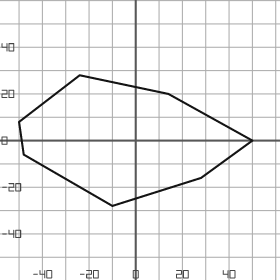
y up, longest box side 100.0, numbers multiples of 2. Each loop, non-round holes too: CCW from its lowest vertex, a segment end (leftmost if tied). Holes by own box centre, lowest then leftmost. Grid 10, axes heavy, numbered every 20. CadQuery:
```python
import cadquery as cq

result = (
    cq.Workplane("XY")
    .moveTo(-10.0, -28.0)
    .lineTo(28.0, -16.0)
    .lineTo(50.0, 0.0)
    .lineTo(14.0, 20.0)
    .lineTo(-24.0, 28.0)
    .lineTo(-50.0, 8.0)
    .lineTo(-48.0, -6.0)
    .close()
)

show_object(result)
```